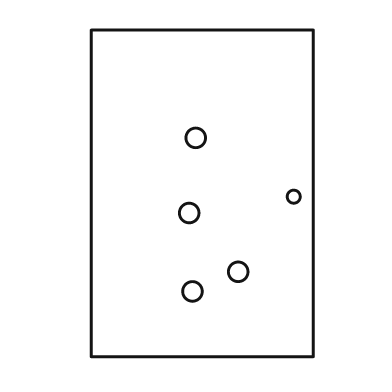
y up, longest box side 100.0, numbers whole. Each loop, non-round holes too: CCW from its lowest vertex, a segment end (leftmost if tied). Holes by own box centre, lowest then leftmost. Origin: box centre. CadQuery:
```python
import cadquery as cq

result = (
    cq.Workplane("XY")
    .moveTo(-34.0, -50.0)
    .lineTo(34.0, -50.0)
    .lineTo(34.0, 50.0)
    .lineTo(-34.0, 50.0)
    .close()
    .moveTo(-3.0, -30.0)
    .circle(3.0)
    .moveTo(11.0, -24.0)
    .circle(3.0)
    .moveTo(-4.0, -6.0)
    .circle(3.0)
    .moveTo(28.0, -1.0)
    .circle(2.0)
    .moveTo(-2.0, 17.0)
    .circle(3.0)
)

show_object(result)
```